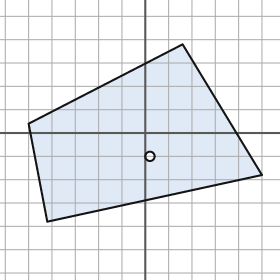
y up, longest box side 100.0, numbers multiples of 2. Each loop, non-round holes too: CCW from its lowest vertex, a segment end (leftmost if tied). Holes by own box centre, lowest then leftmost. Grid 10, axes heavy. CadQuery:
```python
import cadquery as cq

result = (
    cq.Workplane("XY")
    .moveTo(-42.0, -38.0)
    .lineTo(50.0, -18.0)
    .lineTo(16.0, 38.0)
    .lineTo(-50.0, 4.0)
    .close()
    .moveTo(2.0, -10.0)
    .circle(2.0)
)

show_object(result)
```